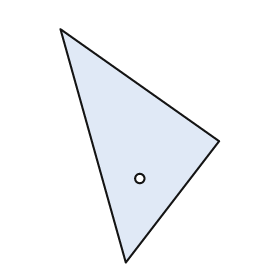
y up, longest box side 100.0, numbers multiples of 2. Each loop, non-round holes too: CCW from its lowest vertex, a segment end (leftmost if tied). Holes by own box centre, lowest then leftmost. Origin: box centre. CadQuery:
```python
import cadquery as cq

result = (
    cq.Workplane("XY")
    .moveTo(-6.0, -50.0)
    .lineTo(34.0, 2.0)
    .lineTo(-34.0, 50.0)
    .close()
    .moveTo(0.0, -14.0)
    .circle(2.0)
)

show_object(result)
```